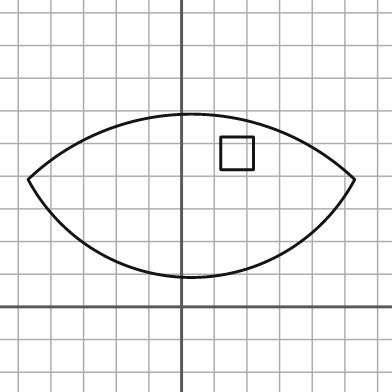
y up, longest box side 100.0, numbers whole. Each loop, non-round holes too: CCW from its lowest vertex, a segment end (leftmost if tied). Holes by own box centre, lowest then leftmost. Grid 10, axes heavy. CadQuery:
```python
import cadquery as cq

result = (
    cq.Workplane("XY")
    .moveTo(-47.0, 39.0)
    .threePointArc((3.0, 9.0), (53.0, 39.0))
    .threePointArc((3.0, 59.0), (-47.0, 39.0))
    .close()
    .moveTo(12.0, 42.0)
    .lineTo(22.0, 42.0)
    .lineTo(22.0, 52.0)
    .lineTo(12.0, 52.0)
    .close()
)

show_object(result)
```